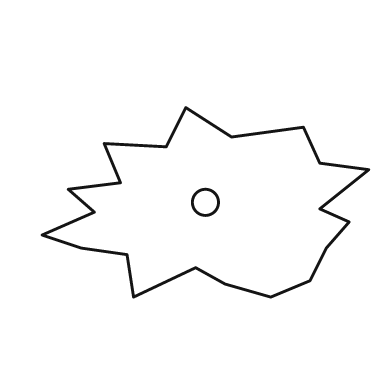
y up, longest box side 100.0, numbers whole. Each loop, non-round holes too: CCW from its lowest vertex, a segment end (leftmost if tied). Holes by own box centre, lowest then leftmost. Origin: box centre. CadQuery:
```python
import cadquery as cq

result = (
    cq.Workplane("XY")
    .moveTo(-22.0, -29.0)
    .lineTo(-3.0, -20.0)
    .lineTo(6.0, -25.0)
    .lineTo(20.0, -29.0)
    .lineTo(32.0, -24.0)
    .lineTo(37.0, -14.0)
    .lineTo(44.0, -6.0)
    .lineTo(35.0, -2.0)
    .lineTo(50.0, 10.0)
    .lineTo(35.0, 12.0)
    .lineTo(30.0, 23.0)
    .lineTo(8.0, 20.0)
    .lineTo(-6.0, 29.0)
    .lineTo(-12.0, 17.0)
    .lineTo(-31.0, 18.0)
    .lineTo(-26.0, 6.0)
    .lineTo(-42.0, 4.0)
    .lineTo(-34.0, -3.0)
    .lineTo(-50.0, -10.0)
    .lineTo(-38.0, -14.0)
    .lineTo(-24.0, -16.0)
    .close()
    .moveTo(0.0, 0.0)
    .circle(4.0)
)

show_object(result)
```